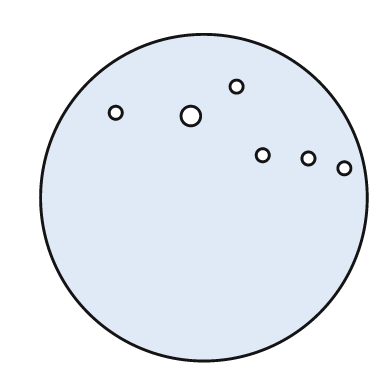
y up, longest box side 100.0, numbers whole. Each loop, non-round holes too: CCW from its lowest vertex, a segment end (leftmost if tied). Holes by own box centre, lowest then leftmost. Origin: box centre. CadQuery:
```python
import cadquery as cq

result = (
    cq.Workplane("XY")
    .moveTo(0.0, 0.0)
    .circle(50.0)
    .moveTo(43.0, 9.0)
    .circle(2.0)
    .moveTo(32.0, 12.0)
    .circle(2.0)
    .moveTo(18.0, 13.0)
    .circle(2.0)
    .moveTo(-4.0, 25.0)
    .circle(3.0)
    .moveTo(-27.0, 26.0)
    .circle(2.0)
    .moveTo(10.0, 34.0)
    .circle(2.0)
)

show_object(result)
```